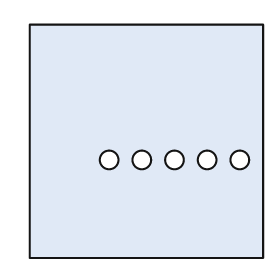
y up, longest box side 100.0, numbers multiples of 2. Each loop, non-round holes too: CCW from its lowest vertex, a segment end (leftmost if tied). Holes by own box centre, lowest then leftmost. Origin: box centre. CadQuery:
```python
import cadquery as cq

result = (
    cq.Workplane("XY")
    .moveTo(-50.0, -50.0)
    .lineTo(50.0, -50.0)
    .lineTo(50.0, 50.0)
    .lineTo(-50.0, 50.0)
    .close()
    .moveTo(-16.0, -8.0)
    .circle(4.0)
    .moveTo(-2.0, -8.0)
    .circle(4.0)
    .moveTo(12.0, -8.0)
    .circle(4.0)
    .moveTo(26.0, -8.0)
    .circle(4.0)
    .moveTo(40.0, -8.0)
    .circle(4.0)
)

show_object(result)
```